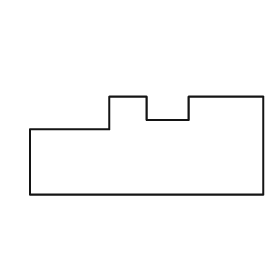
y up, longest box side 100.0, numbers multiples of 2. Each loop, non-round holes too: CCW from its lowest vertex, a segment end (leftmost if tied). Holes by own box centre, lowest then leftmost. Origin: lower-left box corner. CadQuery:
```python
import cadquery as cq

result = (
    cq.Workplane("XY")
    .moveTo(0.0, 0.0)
    .lineTo(100.0, 0.0)
    .lineTo(100.0, 42.0)
    .lineTo(68.0, 42.0)
    .lineTo(68.0, 32.0)
    .lineTo(50.0, 32.0)
    .lineTo(50.0, 42.0)
    .lineTo(34.0, 42.0)
    .lineTo(34.0, 28.0)
    .lineTo(0.0, 28.0)
    .close()
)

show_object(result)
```